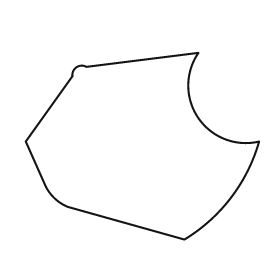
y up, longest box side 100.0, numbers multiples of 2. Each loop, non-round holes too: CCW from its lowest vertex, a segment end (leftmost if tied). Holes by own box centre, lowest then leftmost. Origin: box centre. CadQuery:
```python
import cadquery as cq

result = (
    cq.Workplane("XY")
    .moveTo(18.0, -40.0)
    .threePointArc((38.0, -22.0), (50.0, 2.0))
    .threePointArc((24.0, 12.0), (24.0, 40.0))
    .lineTo(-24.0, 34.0)
    .threePointArc((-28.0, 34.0), (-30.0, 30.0))
    .lineTo(-50.0, 2.0)
    .lineTo(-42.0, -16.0)
    .threePointArc((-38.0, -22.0), (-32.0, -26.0))
    .close()
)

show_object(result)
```